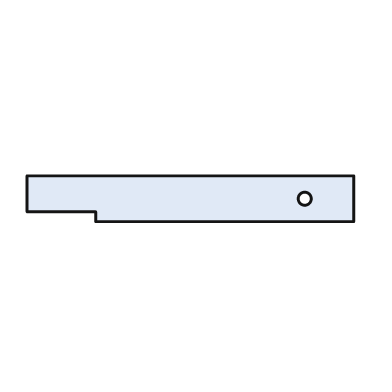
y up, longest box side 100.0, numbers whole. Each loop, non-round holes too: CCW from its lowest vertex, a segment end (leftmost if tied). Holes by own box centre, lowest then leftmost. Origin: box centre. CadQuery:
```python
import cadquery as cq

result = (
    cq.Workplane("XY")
    .moveTo(-29.0, -7.0)
    .lineTo(50.0, -7.0)
    .lineTo(50.0, 7.0)
    .lineTo(-50.0, 7.0)
    .lineTo(-50.0, -4.0)
    .lineTo(-29.0, -4.0)
    .close()
    .moveTo(35.0, 0.0)
    .circle(2.0)
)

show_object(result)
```